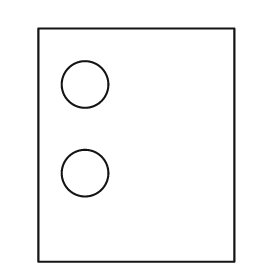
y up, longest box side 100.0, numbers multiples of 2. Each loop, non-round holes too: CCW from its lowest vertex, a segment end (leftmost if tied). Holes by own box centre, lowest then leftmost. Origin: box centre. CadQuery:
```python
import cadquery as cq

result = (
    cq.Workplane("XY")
    .moveTo(-42.0, -50.0)
    .lineTo(42.0, -50.0)
    .lineTo(42.0, 50.0)
    .lineTo(-42.0, 50.0)
    .close()
    .moveTo(-22.0, -12.0)
    .circle(10.0)
    .moveTo(-22.0, 26.0)
    .circle(10.0)
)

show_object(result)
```